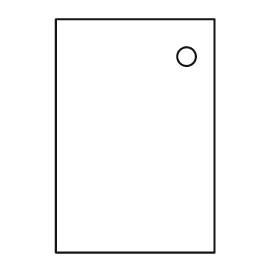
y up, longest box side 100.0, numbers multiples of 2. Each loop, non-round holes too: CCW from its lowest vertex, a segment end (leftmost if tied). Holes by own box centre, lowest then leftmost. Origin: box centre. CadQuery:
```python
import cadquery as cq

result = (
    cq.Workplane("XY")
    .moveTo(-34.0, -50.0)
    .lineTo(34.0, -50.0)
    .lineTo(34.0, 50.0)
    .lineTo(-34.0, 50.0)
    .close()
    .moveTo(22.0, 34.0)
    .circle(4.0)
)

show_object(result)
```